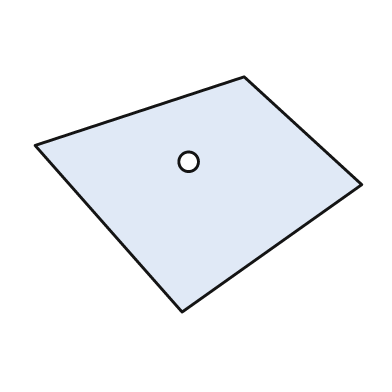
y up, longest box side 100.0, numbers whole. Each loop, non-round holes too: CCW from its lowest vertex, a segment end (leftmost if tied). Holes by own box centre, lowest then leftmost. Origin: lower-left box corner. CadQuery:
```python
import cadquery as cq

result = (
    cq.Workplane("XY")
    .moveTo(45.0, 0.0)
    .lineTo(100.0, 39.0)
    .lineTo(64.0, 72.0)
    .lineTo(0.0, 51.0)
    .close()
    .moveTo(47.0, 46.0)
    .circle(3.0)
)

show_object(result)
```